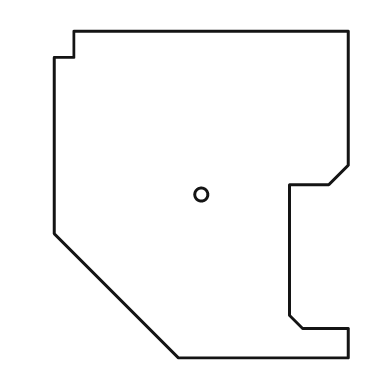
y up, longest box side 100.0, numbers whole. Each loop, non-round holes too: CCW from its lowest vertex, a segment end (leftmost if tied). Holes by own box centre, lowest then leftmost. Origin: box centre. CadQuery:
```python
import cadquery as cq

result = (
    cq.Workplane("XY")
    .moveTo(-7.0, -50.0)
    .lineTo(45.0, -50.0)
    .lineTo(45.0, -41.0)
    .lineTo(31.0, -41.0)
    .lineTo(27.0, -37.0)
    .lineTo(27.0, 3.0)
    .lineTo(39.0, 3.0)
    .lineTo(45.0, 9.0)
    .lineTo(45.0, 50.0)
    .lineTo(-39.0, 50.0)
    .lineTo(-39.0, 42.0)
    .lineTo(-45.0, 42.0)
    .lineTo(-45.0, -12.0)
    .close()
    .moveTo(0.0, 0.0)
    .circle(2.0)
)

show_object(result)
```